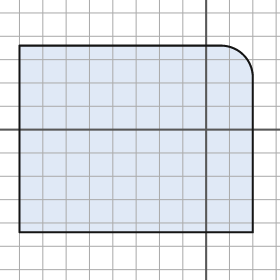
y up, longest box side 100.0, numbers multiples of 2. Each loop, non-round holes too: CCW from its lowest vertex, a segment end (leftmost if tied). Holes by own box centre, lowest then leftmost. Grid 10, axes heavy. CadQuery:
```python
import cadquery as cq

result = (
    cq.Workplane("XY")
    .moveTo(-80.0, -44.0)
    .lineTo(20.0, -44.0)
    .lineTo(20.0, 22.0)
    .threePointArc((16.0, 32.0), (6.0, 36.0))
    .lineTo(-80.0, 36.0)
    .close()
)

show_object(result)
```